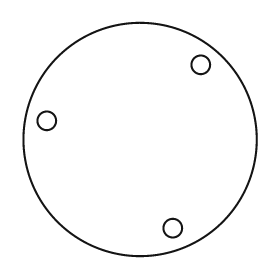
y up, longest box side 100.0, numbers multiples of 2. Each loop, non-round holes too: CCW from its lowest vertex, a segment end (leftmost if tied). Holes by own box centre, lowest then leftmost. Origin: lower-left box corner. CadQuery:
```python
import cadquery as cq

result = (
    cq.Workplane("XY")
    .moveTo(50.0, 50.0)
    .circle(50.0)
    .moveTo(64.0, 12.0)
    .circle(4.0)
    .moveTo(10.0, 58.0)
    .circle(4.0)
    .moveTo(76.0, 82.0)
    .circle(4.0)
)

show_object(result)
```